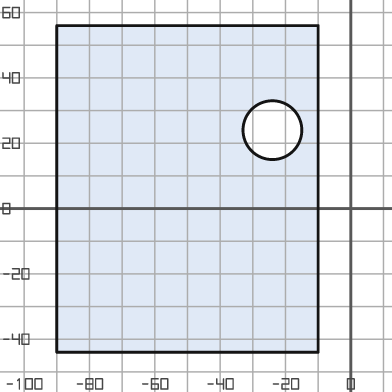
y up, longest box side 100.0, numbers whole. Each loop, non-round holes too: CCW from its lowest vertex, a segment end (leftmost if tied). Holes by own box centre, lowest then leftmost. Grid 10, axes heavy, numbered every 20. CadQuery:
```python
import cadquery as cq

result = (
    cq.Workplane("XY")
    .moveTo(-90.0, -44.0)
    .lineTo(-10.0, -44.0)
    .lineTo(-10.0, 56.0)
    .lineTo(-90.0, 56.0)
    .close()
    .moveTo(-24.0, 24.0)
    .circle(9.0)
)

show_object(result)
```